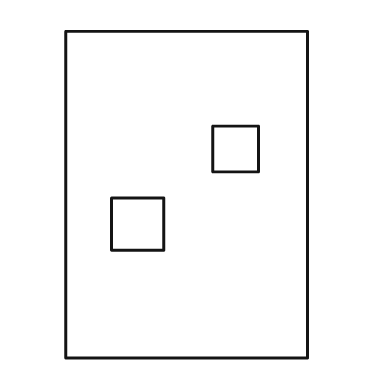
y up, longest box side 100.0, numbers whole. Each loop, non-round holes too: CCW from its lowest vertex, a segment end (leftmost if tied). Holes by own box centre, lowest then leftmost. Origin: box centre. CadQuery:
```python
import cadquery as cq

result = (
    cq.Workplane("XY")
    .moveTo(-37.0, -50.0)
    .lineTo(37.0, -50.0)
    .lineTo(37.0, 50.0)
    .lineTo(-37.0, 50.0)
    .close()
    .moveTo(-23.0, -17.0)
    .lineTo(-7.0, -17.0)
    .lineTo(-7.0, -1.0)
    .lineTo(-23.0, -1.0)
    .close()
    .moveTo(8.0, 7.0)
    .lineTo(22.0, 7.0)
    .lineTo(22.0, 21.0)
    .lineTo(8.0, 21.0)
    .close()
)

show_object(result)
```